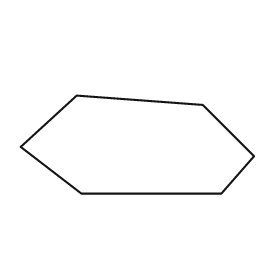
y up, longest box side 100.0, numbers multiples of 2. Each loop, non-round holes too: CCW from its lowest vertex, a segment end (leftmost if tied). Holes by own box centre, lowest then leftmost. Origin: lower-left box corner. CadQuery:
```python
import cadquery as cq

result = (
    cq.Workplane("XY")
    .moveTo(26.0, 0.0)
    .lineTo(86.0, 0.0)
    .lineTo(100.0, 16.0)
    .lineTo(78.0, 38.0)
    .lineTo(24.0, 42.0)
    .lineTo(0.0, 20.0)
    .close()
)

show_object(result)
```